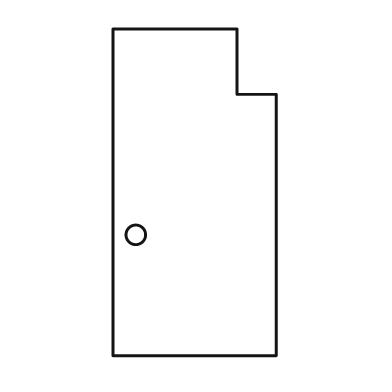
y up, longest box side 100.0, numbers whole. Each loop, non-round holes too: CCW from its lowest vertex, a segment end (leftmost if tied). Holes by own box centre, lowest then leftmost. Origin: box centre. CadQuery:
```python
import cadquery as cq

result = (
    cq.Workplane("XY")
    .moveTo(-25.0, -50.0)
    .lineTo(25.0, -50.0)
    .lineTo(25.0, 30.0)
    .lineTo(13.0, 30.0)
    .lineTo(13.0, 50.0)
    .lineTo(-25.0, 50.0)
    .close()
    .moveTo(-18.0, -13.0)
    .circle(3.0)
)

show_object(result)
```